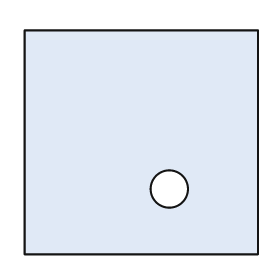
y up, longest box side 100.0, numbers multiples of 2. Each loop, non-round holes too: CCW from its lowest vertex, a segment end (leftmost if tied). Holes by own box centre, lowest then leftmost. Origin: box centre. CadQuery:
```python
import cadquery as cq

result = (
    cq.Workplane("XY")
    .moveTo(-50.0, -48.0)
    .lineTo(50.0, -48.0)
    .lineTo(50.0, 48.0)
    .lineTo(-50.0, 48.0)
    .close()
    .moveTo(12.0, -20.0)
    .circle(8.0)
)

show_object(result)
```